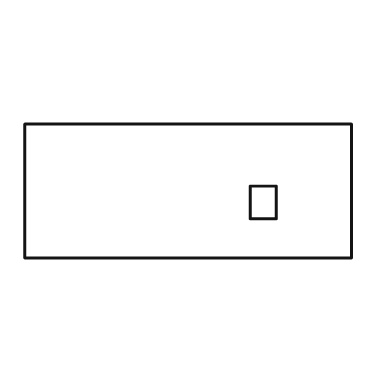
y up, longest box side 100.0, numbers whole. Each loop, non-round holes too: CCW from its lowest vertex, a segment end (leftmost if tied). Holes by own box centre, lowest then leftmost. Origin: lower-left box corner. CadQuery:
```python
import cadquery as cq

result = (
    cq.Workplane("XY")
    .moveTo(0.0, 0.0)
    .lineTo(100.0, 0.0)
    .lineTo(100.0, 41.0)
    .lineTo(0.0, 41.0)
    .close()
    .moveTo(69.0, 12.0)
    .lineTo(77.0, 12.0)
    .lineTo(77.0, 22.0)
    .lineTo(69.0, 22.0)
    .close()
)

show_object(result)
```